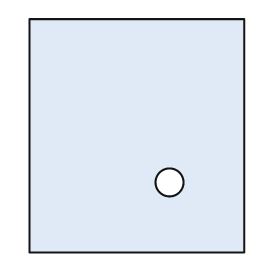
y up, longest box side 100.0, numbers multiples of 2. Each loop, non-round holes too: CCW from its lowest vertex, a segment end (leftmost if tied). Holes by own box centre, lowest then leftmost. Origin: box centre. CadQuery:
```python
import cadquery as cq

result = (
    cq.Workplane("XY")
    .moveTo(-46.0, -50.0)
    .lineTo(46.0, -50.0)
    .lineTo(46.0, 50.0)
    .lineTo(-46.0, 50.0)
    .close()
    .moveTo(14.0, -20.0)
    .circle(6.0)
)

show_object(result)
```